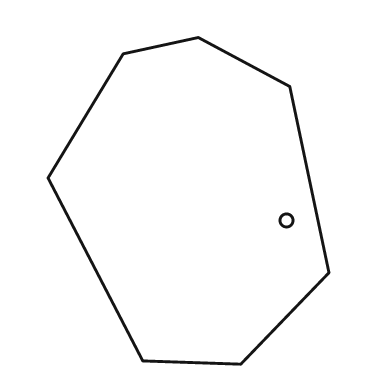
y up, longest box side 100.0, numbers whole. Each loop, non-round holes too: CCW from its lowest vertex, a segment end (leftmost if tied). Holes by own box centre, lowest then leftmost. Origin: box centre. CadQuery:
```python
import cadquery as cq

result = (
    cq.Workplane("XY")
    .moveTo(16.0, -50.0)
    .lineTo(43.0, -22.0)
    .lineTo(31.0, 35.0)
    .lineTo(3.0, 50.0)
    .lineTo(-20.0, 45.0)
    .lineTo(-43.0, 7.0)
    .lineTo(-14.0, -49.0)
    .close()
    .moveTo(30.0, -6.0)
    .circle(2.0)
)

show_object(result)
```